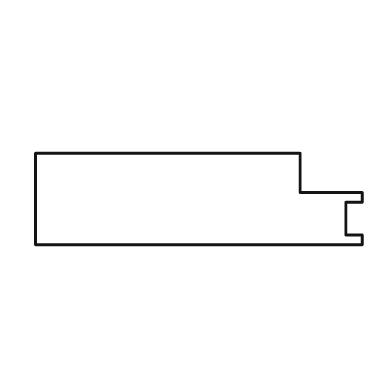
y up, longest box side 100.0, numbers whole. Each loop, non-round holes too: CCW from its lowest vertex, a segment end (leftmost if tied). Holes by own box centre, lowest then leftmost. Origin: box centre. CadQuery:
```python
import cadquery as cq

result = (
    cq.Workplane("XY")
    .moveTo(-50.0, -14.0)
    .lineTo(50.0, -14.0)
    .lineTo(50.0, -11.0)
    .lineTo(45.0, -11.0)
    .lineTo(45.0, -1.0)
    .lineTo(50.0, -1.0)
    .lineTo(50.0, 2.0)
    .lineTo(31.0, 2.0)
    .lineTo(31.0, 14.0)
    .lineTo(-50.0, 14.0)
    .close()
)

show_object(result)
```